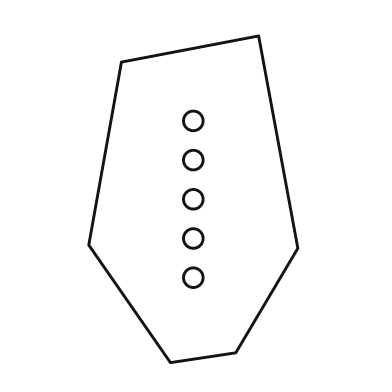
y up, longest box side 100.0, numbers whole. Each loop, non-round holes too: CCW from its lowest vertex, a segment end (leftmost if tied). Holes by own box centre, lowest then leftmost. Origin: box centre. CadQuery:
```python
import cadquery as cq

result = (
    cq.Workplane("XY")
    .moveTo(-7.0, -50.0)
    .lineTo(13.0, -47.0)
    .lineTo(32.0, -15.0)
    .lineTo(20.0, 50.0)
    .lineTo(-22.0, 42.0)
    .lineTo(-32.0, -14.0)
    .close()
    .moveTo(0.0, -24.0)
    .circle(3.0)
    .moveTo(0.0, -12.0)
    .circle(3.0)
    .moveTo(0.0, 0.0)
    .circle(3.0)
    .moveTo(0.0, 12.0)
    .circle(3.0)
    .moveTo(0.0, 24.0)
    .circle(3.0)
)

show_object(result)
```